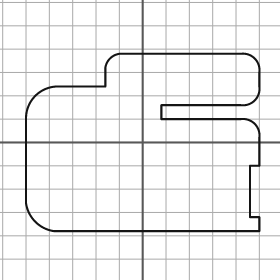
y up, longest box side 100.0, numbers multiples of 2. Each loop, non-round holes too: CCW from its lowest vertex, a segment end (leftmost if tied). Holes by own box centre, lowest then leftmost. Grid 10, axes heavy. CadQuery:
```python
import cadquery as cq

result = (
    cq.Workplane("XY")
    .moveTo(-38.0, -38.0)
    .lineTo(50.0, -38.0)
    .lineTo(50.0, -32.0)
    .lineTo(46.0, -32.0)
    .lineTo(46.0, -10.0)
    .lineTo(50.0, -10.0)
    .lineTo(50.0, 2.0)
    .threePointArc((48.0, 8.0), (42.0, 10.0))
    .lineTo(8.0, 10.0)
    .lineTo(8.0, 16.0)
    .lineTo(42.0, 16.0)
    .threePointArc((48.0, 18.0), (50.0, 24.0))
    .lineTo(50.0, 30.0)
    .threePointArc((48.0, 36.0), (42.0, 38.0))
    .lineTo(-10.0, 38.0)
    .threePointArc((-14.0, 36.0), (-16.0, 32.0))
    .lineTo(-16.0, 24.0)
    .lineTo(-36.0, 24.0)
    .threePointArc((-46.0, 20.0), (-50.0, 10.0))
    .lineTo(-50.0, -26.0)
    .threePointArc((-46.0, -34.0), (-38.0, -38.0))
    .close()
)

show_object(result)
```